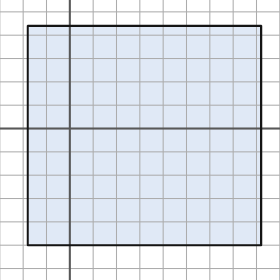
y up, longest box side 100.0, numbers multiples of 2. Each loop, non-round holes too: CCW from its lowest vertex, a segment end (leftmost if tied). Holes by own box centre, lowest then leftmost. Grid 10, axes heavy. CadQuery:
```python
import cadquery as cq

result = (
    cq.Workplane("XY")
    .moveTo(-18.0, -50.0)
    .lineTo(82.0, -50.0)
    .lineTo(82.0, 44.0)
    .lineTo(-18.0, 44.0)
    .close()
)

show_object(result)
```